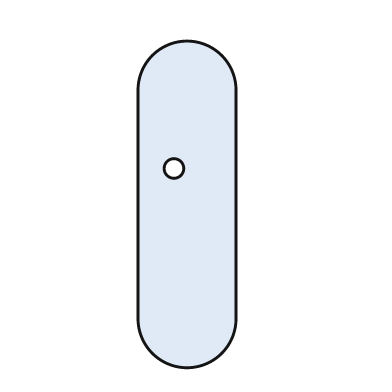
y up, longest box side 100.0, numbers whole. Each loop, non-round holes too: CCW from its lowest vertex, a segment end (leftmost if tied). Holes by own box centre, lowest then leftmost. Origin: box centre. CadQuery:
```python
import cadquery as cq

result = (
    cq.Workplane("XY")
    .moveTo(-15.0, -35.0)
    .threePointArc((0.0, -50.0), (15.0, -35.0))
    .lineTo(15.0, 35.0)
    .threePointArc((0.0, 50.0), (-15.0, 35.0))
    .close()
    .moveTo(-4.0, 11.0)
    .circle(3.0)
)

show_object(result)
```